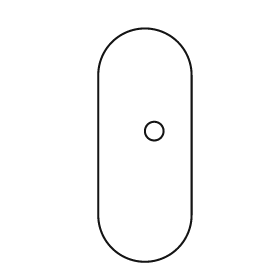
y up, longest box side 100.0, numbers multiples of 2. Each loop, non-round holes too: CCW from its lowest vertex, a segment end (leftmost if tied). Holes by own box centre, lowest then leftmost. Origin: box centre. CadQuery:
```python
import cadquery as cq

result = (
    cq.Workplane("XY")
    .moveTo(-20.0, -30.0)
    .threePointArc((0.0, -50.0), (20.0, -30.0))
    .lineTo(20.0, 30.0)
    .threePointArc((0.0, 50.0), (-20.0, 30.0))
    .close()
    .moveTo(4.0, 6.0)
    .circle(4.0)
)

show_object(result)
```